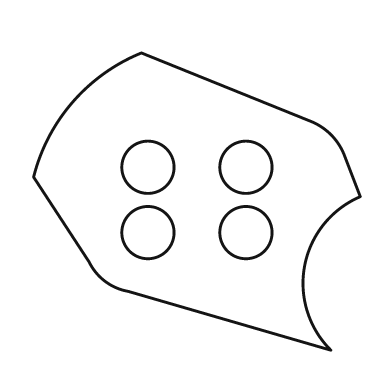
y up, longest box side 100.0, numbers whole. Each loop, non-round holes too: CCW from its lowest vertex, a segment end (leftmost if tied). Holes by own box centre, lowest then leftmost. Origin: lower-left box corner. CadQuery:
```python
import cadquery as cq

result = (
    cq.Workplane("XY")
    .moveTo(91.0, 0.0)
    .threePointArc((83.0, 26.0), (100.0, 47.0))
    .lineTo(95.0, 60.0)
    .threePointArc((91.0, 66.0), (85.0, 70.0))
    .lineTo(33.0, 91.0)
    .threePointArc((12.0, 76.0), (0.0, 53.0))
    .lineTo(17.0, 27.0)
    .threePointArc((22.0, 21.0), (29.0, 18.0))
    .close()
    .moveTo(35.0, 36.0)
    .circle(8.0)
    .moveTo(65.0, 36.0)
    .circle(8.0)
    .moveTo(35.0, 56.0)
    .circle(8.0)
    .moveTo(65.0, 56.0)
    .circle(8.0)
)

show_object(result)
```